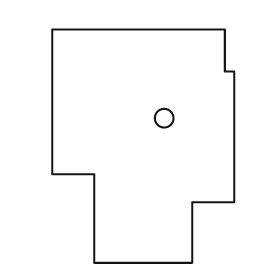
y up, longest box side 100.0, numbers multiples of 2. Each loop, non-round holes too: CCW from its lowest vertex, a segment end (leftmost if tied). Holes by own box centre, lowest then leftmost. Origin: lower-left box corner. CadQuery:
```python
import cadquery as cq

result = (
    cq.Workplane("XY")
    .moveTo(18.0, 0.0)
    .lineTo(60.0, 0.0)
    .lineTo(60.0, 26.0)
    .lineTo(78.0, 26.0)
    .lineTo(78.0, 82.0)
    .lineTo(74.0, 82.0)
    .lineTo(74.0, 100.0)
    .lineTo(0.0, 100.0)
    .lineTo(0.0, 38.0)
    .lineTo(18.0, 38.0)
    .close()
    .moveTo(48.0, 62.0)
    .circle(4.0)
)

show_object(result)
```